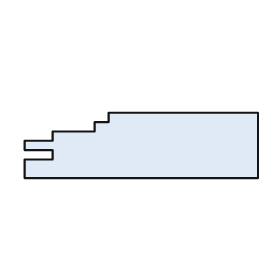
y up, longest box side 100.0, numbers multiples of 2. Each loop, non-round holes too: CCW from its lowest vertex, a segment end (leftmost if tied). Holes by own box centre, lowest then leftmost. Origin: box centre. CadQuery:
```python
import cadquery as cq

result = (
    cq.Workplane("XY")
    .moveTo(-50.0, -14.0)
    .lineTo(50.0, -14.0)
    .lineTo(50.0, 14.0)
    .lineTo(-14.0, 14.0)
    .lineTo(-14.0, 10.0)
    .lineTo(-20.0, 10.0)
    .lineTo(-20.0, 6.0)
    .lineTo(-38.0, 6.0)
    .lineTo(-38.0, 2.0)
    .lineTo(-50.0, 2.0)
    .lineTo(-50.0, -2.0)
    .lineTo(-38.0, -2.0)
    .lineTo(-38.0, -6.0)
    .lineTo(-50.0, -6.0)
    .close()
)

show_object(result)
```